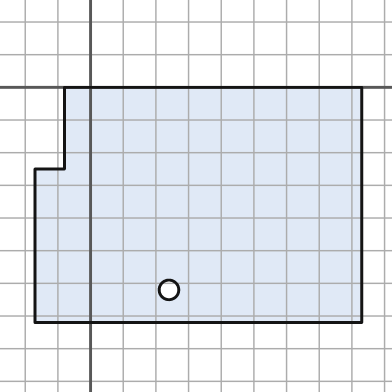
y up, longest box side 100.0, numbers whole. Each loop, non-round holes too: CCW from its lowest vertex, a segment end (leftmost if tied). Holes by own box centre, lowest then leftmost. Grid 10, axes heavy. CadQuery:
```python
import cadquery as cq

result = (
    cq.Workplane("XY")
    .moveTo(-17.0, -72.0)
    .lineTo(83.0, -72.0)
    .lineTo(83.0, 0.0)
    .lineTo(-8.0, 0.0)
    .lineTo(-8.0, -25.0)
    .lineTo(-17.0, -25.0)
    .close()
    .moveTo(24.0, -62.0)
    .circle(3.0)
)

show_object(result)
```